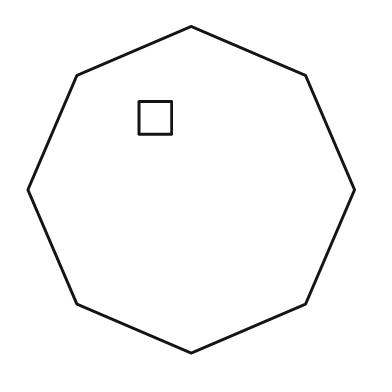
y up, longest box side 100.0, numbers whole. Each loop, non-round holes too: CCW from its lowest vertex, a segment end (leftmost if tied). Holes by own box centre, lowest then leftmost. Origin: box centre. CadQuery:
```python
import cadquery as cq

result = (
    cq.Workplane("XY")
    .moveTo(0.0, -50.0)
    .lineTo(35.0, -35.0)
    .lineTo(50.0, 0.0)
    .lineTo(35.0, 35.0)
    .lineTo(0.0, 50.0)
    .lineTo(-35.0, 35.0)
    .lineTo(-50.0, 0.0)
    .lineTo(-35.0, -35.0)
    .close()
    .moveTo(-16.0, 17.0)
    .lineTo(-6.0, 17.0)
    .lineTo(-6.0, 27.0)
    .lineTo(-16.0, 27.0)
    .close()
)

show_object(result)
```